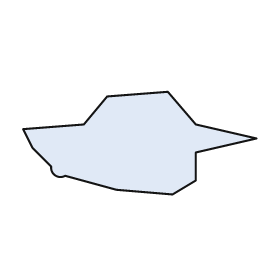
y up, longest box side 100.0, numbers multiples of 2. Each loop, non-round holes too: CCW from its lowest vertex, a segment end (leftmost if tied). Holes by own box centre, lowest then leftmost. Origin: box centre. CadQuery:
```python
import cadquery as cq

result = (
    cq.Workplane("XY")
    .moveTo(14.0, -22.0)
    .lineTo(24.0, -16.0)
    .lineTo(24.0, -4.0)
    .lineTo(50.0, 2.0)
    .lineTo(24.0, 8.0)
    .lineTo(12.0, 22.0)
    .lineTo(-14.0, 20.0)
    .lineTo(-24.0, 8.0)
    .lineTo(-50.0, 6.0)
    .lineTo(-46.0, -2.0)
    .lineTo(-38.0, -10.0)
    .threePointArc((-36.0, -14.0), (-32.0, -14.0))
    .lineTo(-10.0, -20.0)
    .close()
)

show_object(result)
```